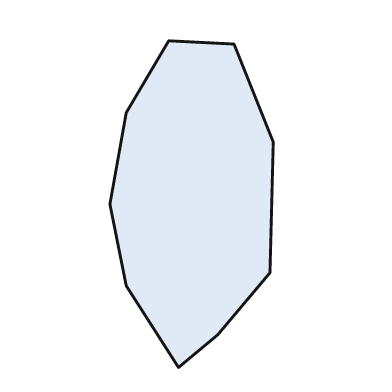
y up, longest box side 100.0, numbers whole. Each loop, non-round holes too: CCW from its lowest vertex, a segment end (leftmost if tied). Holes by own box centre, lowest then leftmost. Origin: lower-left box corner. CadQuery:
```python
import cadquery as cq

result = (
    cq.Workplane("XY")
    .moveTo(21.0, 0.0)
    .lineTo(33.0, 10.0)
    .lineTo(49.0, 29.0)
    .lineTo(50.0, 69.0)
    .lineTo(38.0, 99.0)
    .lineTo(18.0, 100.0)
    .lineTo(5.0, 78.0)
    .lineTo(0.0, 50.0)
    .lineTo(5.0, 25.0)
    .close()
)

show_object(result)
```